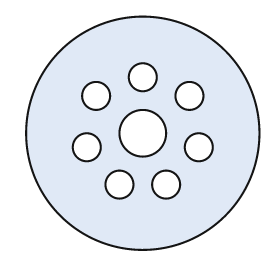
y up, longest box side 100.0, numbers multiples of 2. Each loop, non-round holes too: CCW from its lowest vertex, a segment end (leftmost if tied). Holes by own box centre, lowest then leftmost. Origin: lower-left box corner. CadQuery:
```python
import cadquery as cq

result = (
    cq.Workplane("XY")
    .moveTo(50.0, 50.0)
    .circle(50.0)
    .moveTo(40.0, 28.0)
    .circle(6.0)
    .moveTo(60.0, 28.0)
    .circle(6.0)
    .moveTo(26.0, 44.0)
    .circle(6.0)
    .moveTo(74.0, 44.0)
    .circle(6.0)
    .moveTo(50.0, 50.0)
    .circle(10.0)
    .moveTo(30.0, 66.0)
    .circle(6.0)
    .moveTo(70.0, 66.0)
    .circle(6.0)
    .moveTo(50.0, 74.0)
    .circle(6.0)
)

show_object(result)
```